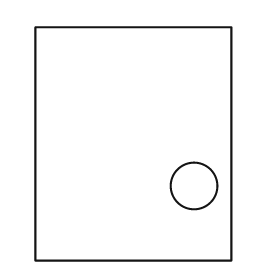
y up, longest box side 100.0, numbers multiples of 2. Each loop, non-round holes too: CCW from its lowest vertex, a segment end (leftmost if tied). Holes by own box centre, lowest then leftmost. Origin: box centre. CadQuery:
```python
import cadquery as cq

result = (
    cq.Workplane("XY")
    .moveTo(-42.0, -50.0)
    .lineTo(42.0, -50.0)
    .lineTo(42.0, 50.0)
    .lineTo(-42.0, 50.0)
    .close()
    .moveTo(26.0, -18.0)
    .circle(10.0)
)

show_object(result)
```